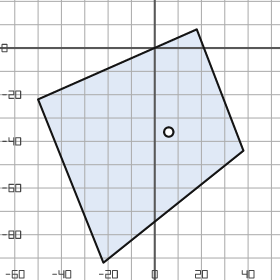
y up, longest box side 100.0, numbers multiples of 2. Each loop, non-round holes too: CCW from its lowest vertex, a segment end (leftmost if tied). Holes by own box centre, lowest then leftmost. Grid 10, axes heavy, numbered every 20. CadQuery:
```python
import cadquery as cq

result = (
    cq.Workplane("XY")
    .moveTo(-22.0, -92.0)
    .lineTo(38.0, -44.0)
    .lineTo(18.0, 8.0)
    .lineTo(-50.0, -22.0)
    .close()
    .moveTo(6.0, -36.0)
    .circle(2.0)
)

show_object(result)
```